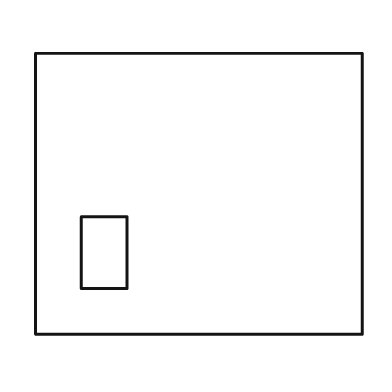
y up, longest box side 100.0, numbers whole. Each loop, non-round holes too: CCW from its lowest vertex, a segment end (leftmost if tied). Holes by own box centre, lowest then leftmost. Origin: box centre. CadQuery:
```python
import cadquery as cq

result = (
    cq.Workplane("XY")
    .moveTo(-50.0, -43.0)
    .lineTo(50.0, -43.0)
    .lineTo(50.0, 43.0)
    .lineTo(-50.0, 43.0)
    .close()
    .moveTo(-36.0, -29.0)
    .lineTo(-22.0, -29.0)
    .lineTo(-22.0, -7.0)
    .lineTo(-36.0, -7.0)
    .close()
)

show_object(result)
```